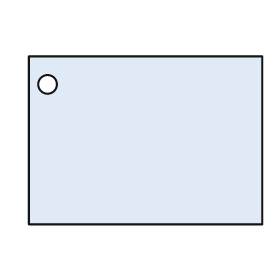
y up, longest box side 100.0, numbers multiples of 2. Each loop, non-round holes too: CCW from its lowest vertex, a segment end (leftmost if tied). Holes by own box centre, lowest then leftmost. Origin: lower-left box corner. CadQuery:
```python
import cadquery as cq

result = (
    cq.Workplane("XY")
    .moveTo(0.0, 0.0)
    .lineTo(100.0, 0.0)
    .lineTo(100.0, 72.0)
    .lineTo(0.0, 72.0)
    .close()
    .moveTo(8.0, 60.0)
    .circle(4.0)
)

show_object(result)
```